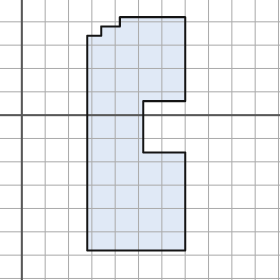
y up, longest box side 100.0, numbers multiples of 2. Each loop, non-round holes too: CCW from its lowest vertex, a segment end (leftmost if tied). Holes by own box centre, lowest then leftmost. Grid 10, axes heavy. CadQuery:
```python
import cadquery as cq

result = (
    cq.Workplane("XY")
    .moveTo(28.0, -58.0)
    .lineTo(70.0, -58.0)
    .lineTo(70.0, -16.0)
    .lineTo(52.0, -16.0)
    .lineTo(52.0, 6.0)
    .lineTo(70.0, 6.0)
    .lineTo(70.0, 42.0)
    .lineTo(42.0, 42.0)
    .lineTo(42.0, 38.0)
    .lineTo(34.0, 38.0)
    .lineTo(34.0, 34.0)
    .lineTo(28.0, 34.0)
    .close()
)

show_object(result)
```